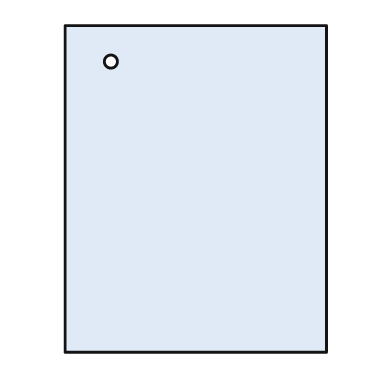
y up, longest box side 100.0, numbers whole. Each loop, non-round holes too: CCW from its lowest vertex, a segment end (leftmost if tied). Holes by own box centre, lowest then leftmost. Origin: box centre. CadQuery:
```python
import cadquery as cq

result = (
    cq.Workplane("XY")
    .moveTo(-40.0, -50.0)
    .lineTo(40.0, -50.0)
    .lineTo(40.0, 50.0)
    .lineTo(-40.0, 50.0)
    .close()
    .moveTo(-26.0, 39.0)
    .circle(2.0)
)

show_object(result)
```